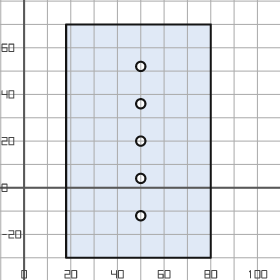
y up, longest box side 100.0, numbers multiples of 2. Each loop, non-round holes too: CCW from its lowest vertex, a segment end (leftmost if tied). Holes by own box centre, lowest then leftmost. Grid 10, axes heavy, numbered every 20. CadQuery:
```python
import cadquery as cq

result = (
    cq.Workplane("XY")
    .moveTo(18.0, -30.0)
    .lineTo(80.0, -30.0)
    .lineTo(80.0, 70.0)
    .lineTo(18.0, 70.0)
    .close()
    .moveTo(50.0, -12.0)
    .circle(2.0)
    .moveTo(50.0, 4.0)
    .circle(2.0)
    .moveTo(50.0, 20.0)
    .circle(2.0)
    .moveTo(50.0, 36.0)
    .circle(2.0)
    .moveTo(50.0, 52.0)
    .circle(2.0)
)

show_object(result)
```